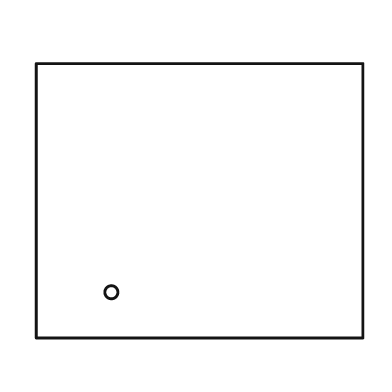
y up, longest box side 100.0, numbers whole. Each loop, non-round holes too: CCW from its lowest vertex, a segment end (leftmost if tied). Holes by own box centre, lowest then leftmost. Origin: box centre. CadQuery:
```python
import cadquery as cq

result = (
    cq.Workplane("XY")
    .moveTo(-50.0, -42.0)
    .lineTo(50.0, -42.0)
    .lineTo(50.0, 42.0)
    .lineTo(-50.0, 42.0)
    .close()
    .moveTo(-27.0, -28.0)
    .circle(2.0)
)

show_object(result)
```